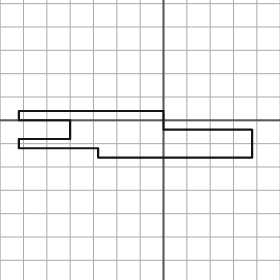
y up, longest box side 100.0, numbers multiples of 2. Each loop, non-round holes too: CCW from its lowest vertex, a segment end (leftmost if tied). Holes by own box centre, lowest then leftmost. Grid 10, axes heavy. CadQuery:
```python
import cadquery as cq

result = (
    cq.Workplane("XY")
    .moveTo(-28.0, -16.0)
    .lineTo(38.0, -16.0)
    .lineTo(38.0, -4.0)
    .lineTo(0.0, -4.0)
    .lineTo(0.0, 4.0)
    .lineTo(-62.0, 4.0)
    .lineTo(-62.0, 0.0)
    .lineTo(-40.0, 0.0)
    .lineTo(-40.0, -8.0)
    .lineTo(-62.0, -8.0)
    .lineTo(-62.0, -12.0)
    .lineTo(-28.0, -12.0)
    .close()
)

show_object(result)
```